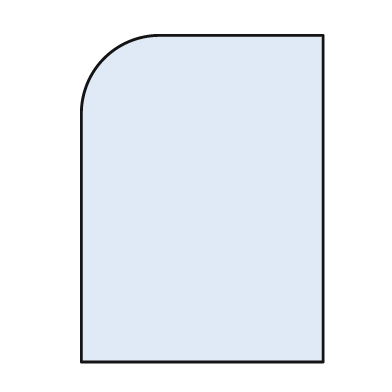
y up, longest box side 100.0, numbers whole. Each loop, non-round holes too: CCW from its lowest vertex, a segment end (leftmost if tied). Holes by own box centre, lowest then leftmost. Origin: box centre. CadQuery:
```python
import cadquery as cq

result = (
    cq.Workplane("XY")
    .moveTo(-37.0, -50.0)
    .lineTo(37.0, -50.0)
    .lineTo(37.0, 50.0)
    .lineTo(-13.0, 50.0)
    .threePointArc((-30.0, 43.0), (-37.0, 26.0))
    .close()
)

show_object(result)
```